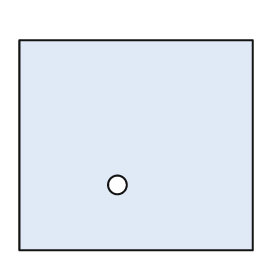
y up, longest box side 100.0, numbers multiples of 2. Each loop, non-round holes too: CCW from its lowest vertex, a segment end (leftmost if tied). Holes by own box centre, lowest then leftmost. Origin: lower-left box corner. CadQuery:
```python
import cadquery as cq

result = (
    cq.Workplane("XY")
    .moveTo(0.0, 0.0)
    .lineTo(100.0, 0.0)
    .lineTo(100.0, 90.0)
    .lineTo(0.0, 90.0)
    .close()
    .moveTo(42.0, 28.0)
    .circle(4.0)
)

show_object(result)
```